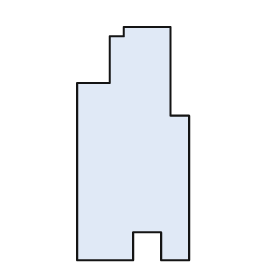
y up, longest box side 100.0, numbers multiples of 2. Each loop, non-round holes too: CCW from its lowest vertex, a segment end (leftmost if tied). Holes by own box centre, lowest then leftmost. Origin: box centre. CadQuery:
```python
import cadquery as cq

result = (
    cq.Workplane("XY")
    .moveTo(-24.0, -50.0)
    .lineTo(0.0, -50.0)
    .lineTo(0.0, -38.0)
    .lineTo(12.0, -38.0)
    .lineTo(12.0, -50.0)
    .lineTo(24.0, -50.0)
    .lineTo(24.0, 12.0)
    .lineTo(16.0, 12.0)
    .lineTo(16.0, 50.0)
    .lineTo(-4.0, 50.0)
    .lineTo(-4.0, 46.0)
    .lineTo(-10.0, 46.0)
    .lineTo(-10.0, 26.0)
    .lineTo(-24.0, 26.0)
    .close()
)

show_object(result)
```